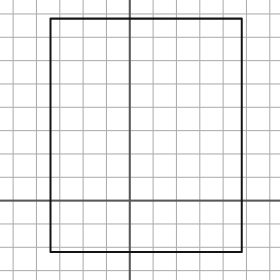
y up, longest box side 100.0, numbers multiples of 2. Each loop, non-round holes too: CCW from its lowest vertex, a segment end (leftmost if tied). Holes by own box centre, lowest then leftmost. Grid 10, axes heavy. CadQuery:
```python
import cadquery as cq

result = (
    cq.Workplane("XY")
    .moveTo(-34.0, -22.0)
    .lineTo(48.0, -22.0)
    .lineTo(48.0, 78.0)
    .lineTo(-34.0, 78.0)
    .close()
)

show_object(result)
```